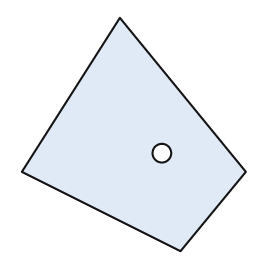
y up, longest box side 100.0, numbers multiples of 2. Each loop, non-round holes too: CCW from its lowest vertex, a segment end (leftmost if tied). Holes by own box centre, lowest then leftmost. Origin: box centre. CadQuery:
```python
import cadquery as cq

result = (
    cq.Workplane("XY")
    .moveTo(20.0, -50.0)
    .lineTo(48.0, -16.0)
    .lineTo(-6.0, 50.0)
    .lineTo(-48.0, -16.0)
    .close()
    .moveTo(12.0, -8.0)
    .circle(4.0)
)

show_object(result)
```